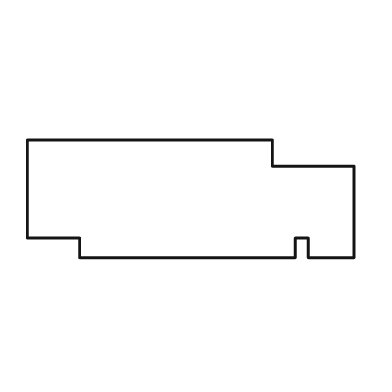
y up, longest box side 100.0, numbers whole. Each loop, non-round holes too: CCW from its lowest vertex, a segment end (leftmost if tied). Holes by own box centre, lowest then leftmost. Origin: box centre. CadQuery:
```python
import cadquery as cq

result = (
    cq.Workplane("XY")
    .moveTo(-34.0, -18.0)
    .lineTo(32.0, -18.0)
    .lineTo(32.0, -12.0)
    .lineTo(36.0, -12.0)
    .lineTo(36.0, -18.0)
    .lineTo(50.0, -18.0)
    .lineTo(50.0, 10.0)
    .lineTo(25.0, 10.0)
    .lineTo(25.0, 18.0)
    .lineTo(-50.0, 18.0)
    .lineTo(-50.0, -12.0)
    .lineTo(-34.0, -12.0)
    .close()
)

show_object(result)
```